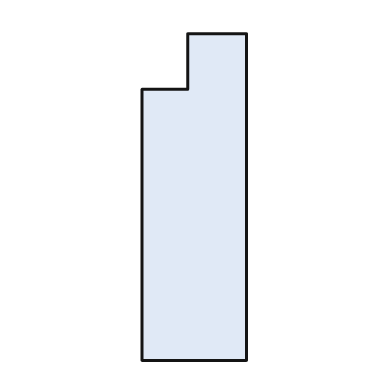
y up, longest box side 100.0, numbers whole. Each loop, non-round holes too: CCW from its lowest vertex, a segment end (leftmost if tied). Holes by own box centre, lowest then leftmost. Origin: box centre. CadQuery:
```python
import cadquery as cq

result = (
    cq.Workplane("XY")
    .moveTo(-16.0, -50.0)
    .lineTo(16.0, -50.0)
    .lineTo(16.0, 50.0)
    .lineTo(-2.0, 50.0)
    .lineTo(-2.0, 33.0)
    .lineTo(-16.0, 33.0)
    .close()
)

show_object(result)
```